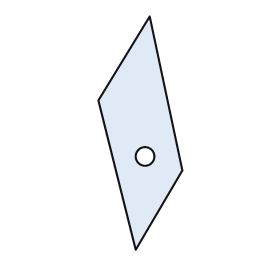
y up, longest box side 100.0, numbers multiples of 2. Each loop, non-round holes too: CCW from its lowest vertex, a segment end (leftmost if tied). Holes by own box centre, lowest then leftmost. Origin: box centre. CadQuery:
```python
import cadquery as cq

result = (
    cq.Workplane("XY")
    .moveTo(-2.0, -50.0)
    .lineTo(18.0, -16.0)
    .lineTo(4.0, 50.0)
    .lineTo(-18.0, 14.0)
    .close()
    .moveTo(2.0, -10.0)
    .circle(4.0)
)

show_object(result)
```